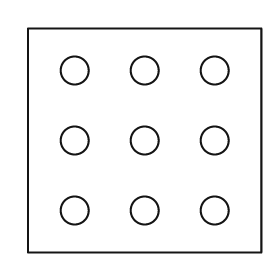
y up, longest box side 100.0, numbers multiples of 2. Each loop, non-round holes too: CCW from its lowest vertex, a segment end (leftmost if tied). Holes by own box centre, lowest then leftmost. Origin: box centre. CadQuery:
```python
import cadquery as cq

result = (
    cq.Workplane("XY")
    .moveTo(-50.0, -48.0)
    .lineTo(50.0, -48.0)
    .lineTo(50.0, 48.0)
    .lineTo(-50.0, 48.0)
    .close()
    .moveTo(-30.0, -30.0)
    .circle(6.0)
    .moveTo(0.0, -30.0)
    .circle(6.0)
    .moveTo(30.0, -30.0)
    .circle(6.0)
    .moveTo(-30.0, 0.0)
    .circle(6.0)
    .moveTo(0.0, 0.0)
    .circle(6.0)
    .moveTo(30.0, 0.0)
    .circle(6.0)
    .moveTo(-30.0, 30.0)
    .circle(6.0)
    .moveTo(0.0, 30.0)
    .circle(6.0)
    .moveTo(30.0, 30.0)
    .circle(6.0)
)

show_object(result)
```